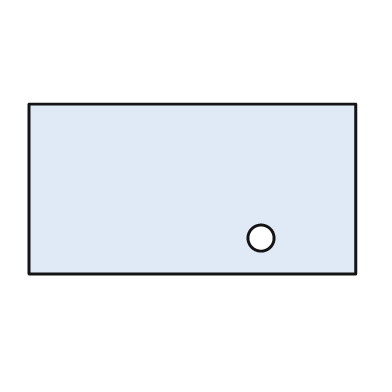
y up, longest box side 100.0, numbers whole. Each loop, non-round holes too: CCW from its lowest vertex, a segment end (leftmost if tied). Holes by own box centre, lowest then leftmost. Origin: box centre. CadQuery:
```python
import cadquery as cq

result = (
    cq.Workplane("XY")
    .moveTo(-50.0, -26.0)
    .lineTo(50.0, -26.0)
    .lineTo(50.0, 26.0)
    .lineTo(-50.0, 26.0)
    .close()
    .moveTo(21.0, -15.0)
    .circle(4.0)
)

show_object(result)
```